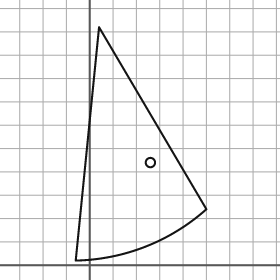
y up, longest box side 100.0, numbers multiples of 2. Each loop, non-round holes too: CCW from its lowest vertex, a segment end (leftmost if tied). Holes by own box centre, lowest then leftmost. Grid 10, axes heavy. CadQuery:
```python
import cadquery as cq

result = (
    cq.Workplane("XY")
    .moveTo(-6.0, 2.0)
    .threePointArc((24.0, 8.0), (50.0, 24.0))
    .lineTo(4.0, 102.0)
    .close()
    .moveTo(26.0, 44.0)
    .circle(2.0)
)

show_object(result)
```